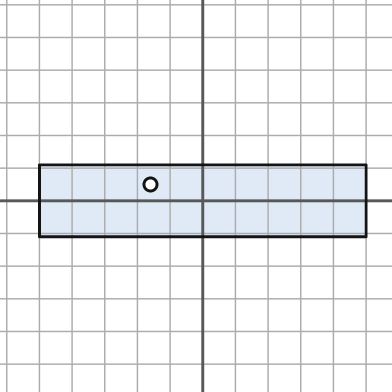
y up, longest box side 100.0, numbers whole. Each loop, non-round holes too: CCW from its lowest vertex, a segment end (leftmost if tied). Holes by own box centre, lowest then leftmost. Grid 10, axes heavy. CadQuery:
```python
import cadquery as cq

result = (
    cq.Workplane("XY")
    .moveTo(-50.0, -11.0)
    .lineTo(50.0, -11.0)
    .lineTo(50.0, 11.0)
    .lineTo(-50.0, 11.0)
    .close()
    .moveTo(-16.0, 5.0)
    .circle(2.0)
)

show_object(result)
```